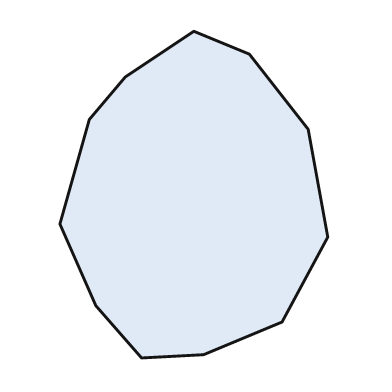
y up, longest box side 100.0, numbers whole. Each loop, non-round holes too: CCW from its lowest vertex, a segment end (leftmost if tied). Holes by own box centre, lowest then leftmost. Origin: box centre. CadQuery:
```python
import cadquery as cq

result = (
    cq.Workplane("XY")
    .moveTo(-16.0, -50.0)
    .lineTo(3.0, -49.0)
    .lineTo(27.0, -39.0)
    .lineTo(41.0, -13.0)
    .lineTo(35.0, 20.0)
    .lineTo(17.0, 43.0)
    .lineTo(0.0, 50.0)
    .lineTo(-21.0, 36.0)
    .lineTo(-32.0, 23.0)
    .lineTo(-41.0, -9.0)
    .lineTo(-30.0, -34.0)
    .close()
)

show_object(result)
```